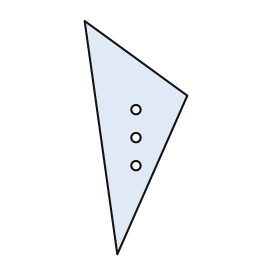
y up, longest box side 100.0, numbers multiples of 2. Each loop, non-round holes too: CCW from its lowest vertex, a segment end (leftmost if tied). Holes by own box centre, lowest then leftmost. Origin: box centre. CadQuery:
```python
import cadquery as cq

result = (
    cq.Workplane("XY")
    .moveTo(-8.0, -50.0)
    .lineTo(22.0, 18.0)
    .lineTo(-22.0, 50.0)
    .close()
    .moveTo(0.0, -12.0)
    .circle(2.0)
    .moveTo(0.0, 0.0)
    .circle(2.0)
    .moveTo(0.0, 12.0)
    .circle(2.0)
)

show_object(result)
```